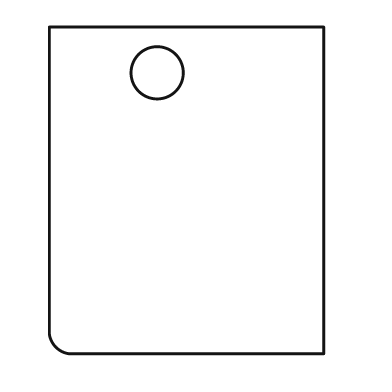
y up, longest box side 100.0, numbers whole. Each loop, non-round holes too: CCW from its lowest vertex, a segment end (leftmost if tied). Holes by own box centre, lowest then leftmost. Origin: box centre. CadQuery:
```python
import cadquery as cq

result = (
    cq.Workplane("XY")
    .moveTo(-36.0, -50.0)
    .lineTo(42.0, -50.0)
    .lineTo(42.0, 50.0)
    .lineTo(-42.0, 50.0)
    .lineTo(-42.0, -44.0)
    .threePointArc((-40.0, -48.0), (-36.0, -50.0))
    .close()
    .moveTo(-9.0, 36.0)
    .circle(8.0)
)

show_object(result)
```